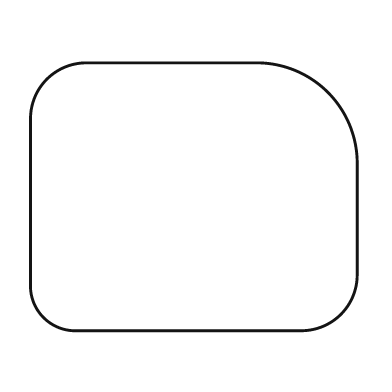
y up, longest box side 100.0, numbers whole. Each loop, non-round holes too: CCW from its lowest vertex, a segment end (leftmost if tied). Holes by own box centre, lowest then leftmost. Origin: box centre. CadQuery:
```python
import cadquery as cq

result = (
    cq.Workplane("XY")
    .moveTo(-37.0, -41.0)
    .lineTo(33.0, -41.0)
    .threePointArc((45.0, -36.0), (50.0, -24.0))
    .lineTo(50.0, 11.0)
    .threePointArc((41.0, 32.0), (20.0, 41.0))
    .lineTo(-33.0, 41.0)
    .threePointArc((-45.0, 36.0), (-50.0, 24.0))
    .lineTo(-50.0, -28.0)
    .threePointArc((-46.0, -37.0), (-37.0, -41.0))
    .close()
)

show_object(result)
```